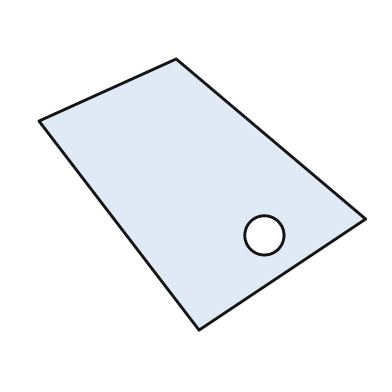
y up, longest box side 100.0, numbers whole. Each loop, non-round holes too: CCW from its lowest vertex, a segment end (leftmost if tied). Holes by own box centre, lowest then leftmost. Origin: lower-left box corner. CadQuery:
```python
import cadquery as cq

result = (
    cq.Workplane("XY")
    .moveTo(49.0, 0.0)
    .lineTo(100.0, 34.0)
    .lineTo(42.0, 83.0)
    .lineTo(0.0, 64.0)
    .close()
    .moveTo(69.0, 29.0)
    .circle(6.0)
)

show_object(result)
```